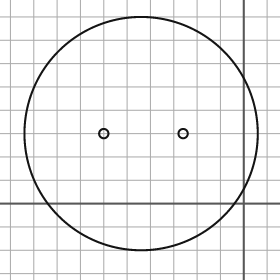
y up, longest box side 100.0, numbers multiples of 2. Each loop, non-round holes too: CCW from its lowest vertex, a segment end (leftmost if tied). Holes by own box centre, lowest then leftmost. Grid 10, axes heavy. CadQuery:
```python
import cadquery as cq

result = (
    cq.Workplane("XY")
    .moveTo(-44.0, 30.0)
    .circle(50.0)
    .moveTo(-60.0, 30.0)
    .circle(2.0)
    .moveTo(-26.0, 30.0)
    .circle(2.0)
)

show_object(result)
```